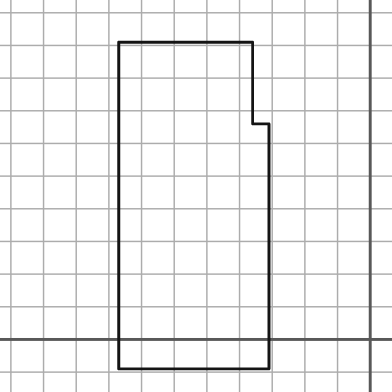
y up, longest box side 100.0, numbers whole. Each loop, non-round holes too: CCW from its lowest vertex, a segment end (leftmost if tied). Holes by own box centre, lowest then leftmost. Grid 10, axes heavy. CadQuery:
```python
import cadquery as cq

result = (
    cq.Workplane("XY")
    .moveTo(-77.0, -9.0)
    .lineTo(-31.0, -9.0)
    .lineTo(-31.0, 66.0)
    .lineTo(-36.0, 66.0)
    .lineTo(-36.0, 91.0)
    .lineTo(-77.0, 91.0)
    .close()
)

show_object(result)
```